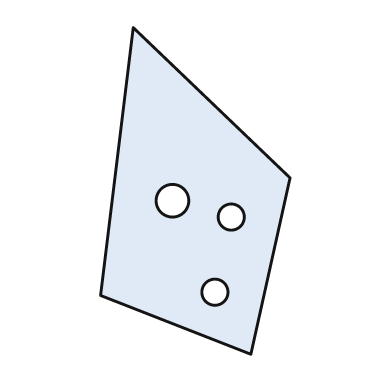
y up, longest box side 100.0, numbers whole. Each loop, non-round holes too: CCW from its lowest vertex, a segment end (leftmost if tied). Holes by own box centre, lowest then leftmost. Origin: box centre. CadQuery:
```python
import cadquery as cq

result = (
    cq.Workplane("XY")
    .moveTo(17.0, -50.0)
    .lineTo(29.0, 4.0)
    .lineTo(-19.0, 50.0)
    .lineTo(-29.0, -32.0)
    .close()
    .moveTo(6.0, -31.0)
    .circle(4.0)
    .moveTo(11.0, -8.0)
    .circle(4.0)
    .moveTo(-7.0, -3.0)
    .circle(5.0)
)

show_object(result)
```